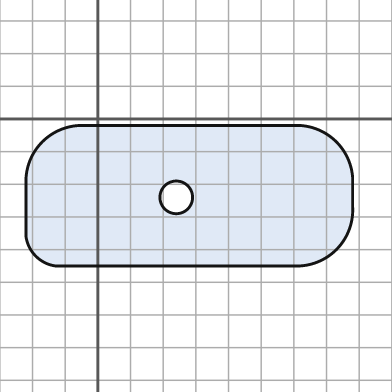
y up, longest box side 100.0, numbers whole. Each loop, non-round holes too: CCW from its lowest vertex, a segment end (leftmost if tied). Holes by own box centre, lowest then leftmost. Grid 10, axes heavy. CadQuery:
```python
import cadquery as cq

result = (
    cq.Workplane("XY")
    .moveTo(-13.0, -45.0)
    .lineTo(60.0, -45.0)
    .threePointArc((73.0, -40.0), (78.0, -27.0))
    .lineTo(78.0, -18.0)
    .threePointArc((73.0, -7.0), (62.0, -2.0))
    .lineTo(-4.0, -2.0)
    .threePointArc((-17.0, -7.0), (-22.0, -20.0))
    .lineTo(-22.0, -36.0)
    .threePointArc((-19.0, -42.0), (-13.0, -45.0))
    .close()
    .moveTo(24.0, -24.0)
    .circle(5.0)
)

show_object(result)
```